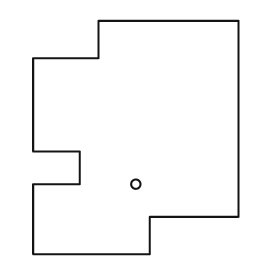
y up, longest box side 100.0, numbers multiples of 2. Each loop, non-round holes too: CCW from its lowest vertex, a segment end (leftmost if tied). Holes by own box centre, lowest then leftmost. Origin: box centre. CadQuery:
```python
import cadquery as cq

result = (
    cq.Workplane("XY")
    .moveTo(-44.0, -50.0)
    .lineTo(6.0, -50.0)
    .lineTo(6.0, -34.0)
    .lineTo(44.0, -34.0)
    .lineTo(44.0, 50.0)
    .lineTo(-16.0, 50.0)
    .lineTo(-16.0, 34.0)
    .lineTo(-44.0, 34.0)
    .lineTo(-44.0, -6.0)
    .lineTo(-24.0, -6.0)
    .lineTo(-24.0, -20.0)
    .lineTo(-44.0, -20.0)
    .close()
    .moveTo(0.0, -20.0)
    .circle(2.0)
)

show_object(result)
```